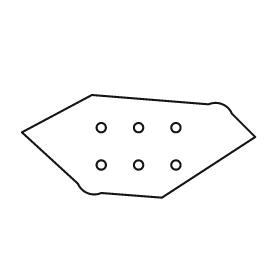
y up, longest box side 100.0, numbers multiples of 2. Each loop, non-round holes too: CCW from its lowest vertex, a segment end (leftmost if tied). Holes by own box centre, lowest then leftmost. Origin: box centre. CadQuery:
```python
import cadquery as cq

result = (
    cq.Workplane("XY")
    .moveTo(10.0, -22.0)
    .lineTo(50.0, 4.0)
    .lineTo(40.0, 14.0)
    .threePointArc((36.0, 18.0), (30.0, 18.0))
    .lineTo(-20.0, 22.0)
    .lineTo(-50.0, 6.0)
    .lineTo(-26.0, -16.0)
    .threePointArc((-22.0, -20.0), (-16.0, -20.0))
    .close()
    .moveTo(-16.0, -8.0)
    .circle(2.0)
    .moveTo(0.0, -8.0)
    .circle(2.0)
    .moveTo(16.0, -8.0)
    .circle(2.0)
    .moveTo(-16.0, 8.0)
    .circle(2.0)
    .moveTo(0.0, 8.0)
    .circle(2.0)
    .moveTo(16.0, 8.0)
    .circle(2.0)
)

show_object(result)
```